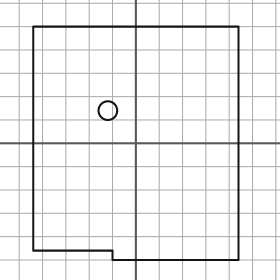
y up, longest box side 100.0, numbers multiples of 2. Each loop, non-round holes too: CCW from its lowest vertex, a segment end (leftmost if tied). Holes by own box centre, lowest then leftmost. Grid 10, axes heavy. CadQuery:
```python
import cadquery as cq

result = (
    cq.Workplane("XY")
    .moveTo(-10.0, -50.0)
    .lineTo(44.0, -50.0)
    .lineTo(44.0, 50.0)
    .lineTo(-44.0, 50.0)
    .lineTo(-44.0, -46.0)
    .lineTo(-10.0, -46.0)
    .close()
    .moveTo(-12.0, 14.0)
    .circle(4.0)
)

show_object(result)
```